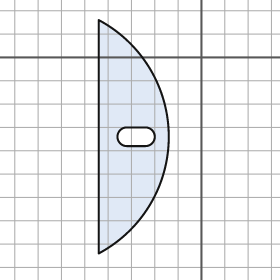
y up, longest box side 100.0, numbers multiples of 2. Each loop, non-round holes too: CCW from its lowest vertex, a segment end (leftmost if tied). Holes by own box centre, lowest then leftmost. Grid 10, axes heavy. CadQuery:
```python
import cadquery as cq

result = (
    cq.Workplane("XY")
    .moveTo(-44.0, -84.0)
    .threePointArc((-14.0, -34.0), (-44.0, 16.0))
    .close()
    .moveTo(-32.0, -38.0)
    .lineTo(-24.0, -38.0)
    .threePointArc((-20.0, -34.0), (-24.0, -30.0))
    .lineTo(-32.0, -30.0)
    .threePointArc((-36.0, -34.0), (-32.0, -38.0))
    .close()
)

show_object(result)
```